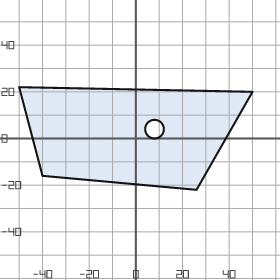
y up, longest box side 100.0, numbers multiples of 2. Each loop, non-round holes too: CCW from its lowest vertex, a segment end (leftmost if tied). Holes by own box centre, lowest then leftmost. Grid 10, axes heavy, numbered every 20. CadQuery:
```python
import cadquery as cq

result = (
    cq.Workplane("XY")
    .moveTo(26.0, -22.0)
    .lineTo(50.0, 20.0)
    .lineTo(-50.0, 22.0)
    .lineTo(-40.0, -16.0)
    .close()
    .moveTo(8.0, 4.0)
    .circle(4.0)
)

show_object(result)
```